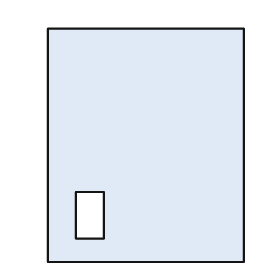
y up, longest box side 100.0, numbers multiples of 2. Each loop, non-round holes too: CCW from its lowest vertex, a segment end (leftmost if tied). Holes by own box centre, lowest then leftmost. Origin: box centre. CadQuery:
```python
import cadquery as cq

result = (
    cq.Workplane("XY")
    .moveTo(-42.0, -50.0)
    .lineTo(42.0, -50.0)
    .lineTo(42.0, 50.0)
    .lineTo(-42.0, 50.0)
    .close()
    .moveTo(-30.0, -40.0)
    .lineTo(-18.0, -40.0)
    .lineTo(-18.0, -20.0)
    .lineTo(-30.0, -20.0)
    .close()
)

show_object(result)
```